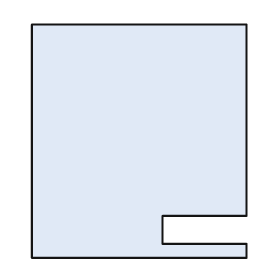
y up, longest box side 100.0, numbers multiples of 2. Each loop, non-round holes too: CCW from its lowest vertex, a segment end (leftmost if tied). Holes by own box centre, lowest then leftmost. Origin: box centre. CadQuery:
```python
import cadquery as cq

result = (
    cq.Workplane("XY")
    .moveTo(-46.0, -50.0)
    .lineTo(46.0, -50.0)
    .lineTo(46.0, -44.0)
    .lineTo(10.0, -44.0)
    .lineTo(10.0, -32.0)
    .lineTo(46.0, -32.0)
    .lineTo(46.0, 50.0)
    .lineTo(-46.0, 50.0)
    .close()
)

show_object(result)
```